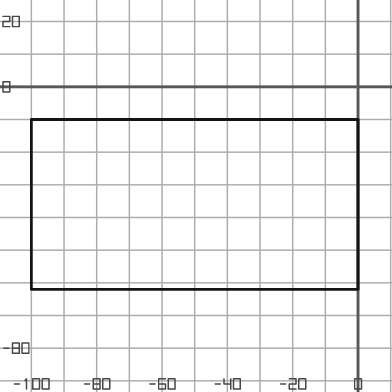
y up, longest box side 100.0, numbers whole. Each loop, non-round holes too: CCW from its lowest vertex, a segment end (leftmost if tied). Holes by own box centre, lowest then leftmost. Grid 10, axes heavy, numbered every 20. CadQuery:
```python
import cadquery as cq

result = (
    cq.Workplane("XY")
    .moveTo(-100.0, -62.0)
    .lineTo(0.0, -62.0)
    .lineTo(0.0, -10.0)
    .lineTo(-100.0, -10.0)
    .close()
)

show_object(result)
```